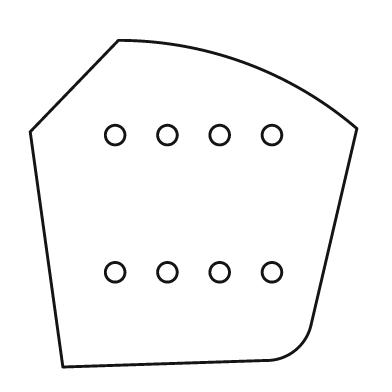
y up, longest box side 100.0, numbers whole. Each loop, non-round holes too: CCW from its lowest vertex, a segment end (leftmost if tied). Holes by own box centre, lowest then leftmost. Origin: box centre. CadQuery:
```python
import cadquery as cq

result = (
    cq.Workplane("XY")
    .moveTo(-40.0, -50.0)
    .lineTo(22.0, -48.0)
    .threePointArc((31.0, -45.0), (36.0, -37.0))
    .lineTo(50.0, 23.0)
    .threePointArc((16.0, 43.0), (-23.0, 50.0))
    .lineTo(-50.0, 22.0)
    .close()
    .moveTo(-24.0, -21.0)
    .circle(3.0)
    .moveTo(-8.0, -21.0)
    .circle(3.0)
    .moveTo(8.0, -21.0)
    .circle(3.0)
    .moveTo(24.0, -21.0)
    .circle(3.0)
    .moveTo(-24.0, 21.0)
    .circle(3.0)
    .moveTo(-8.0, 21.0)
    .circle(3.0)
    .moveTo(8.0, 21.0)
    .circle(3.0)
    .moveTo(24.0, 21.0)
    .circle(3.0)
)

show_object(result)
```